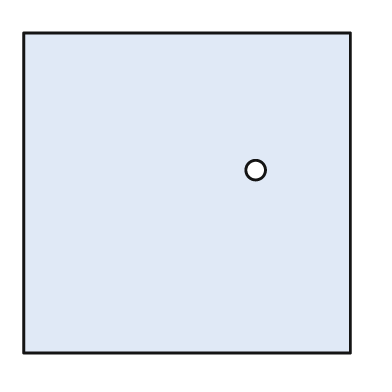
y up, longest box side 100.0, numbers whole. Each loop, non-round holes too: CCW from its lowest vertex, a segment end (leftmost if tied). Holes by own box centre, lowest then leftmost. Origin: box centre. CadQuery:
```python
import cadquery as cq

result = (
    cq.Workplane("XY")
    .moveTo(-50.0, -49.0)
    .lineTo(50.0, -49.0)
    .lineTo(50.0, 49.0)
    .lineTo(-50.0, 49.0)
    .close()
    .moveTo(21.0, 7.0)
    .circle(3.0)
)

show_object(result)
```